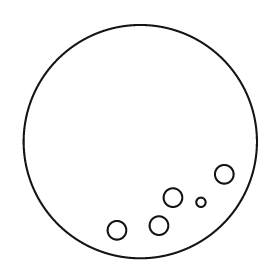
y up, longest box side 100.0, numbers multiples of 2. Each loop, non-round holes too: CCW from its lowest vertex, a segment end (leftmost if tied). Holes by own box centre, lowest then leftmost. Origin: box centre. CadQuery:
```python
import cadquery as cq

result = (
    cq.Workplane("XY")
    .moveTo(0.0, 0.0)
    .circle(50.0)
    .moveTo(-10.0, -38.0)
    .circle(4.0)
    .moveTo(8.0, -36.0)
    .circle(4.0)
    .moveTo(26.0, -26.0)
    .circle(2.0)
    .moveTo(14.0, -24.0)
    .circle(4.0)
    .moveTo(36.0, -14.0)
    .circle(4.0)
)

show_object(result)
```